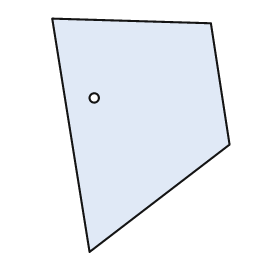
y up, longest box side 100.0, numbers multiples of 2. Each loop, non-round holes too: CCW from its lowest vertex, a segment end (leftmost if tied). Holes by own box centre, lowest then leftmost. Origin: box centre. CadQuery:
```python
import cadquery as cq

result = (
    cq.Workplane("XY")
    .moveTo(-22.0, -50.0)
    .lineTo(38.0, -4.0)
    .lineTo(30.0, 48.0)
    .lineTo(-38.0, 50.0)
    .close()
    .moveTo(-20.0, 16.0)
    .circle(2.0)
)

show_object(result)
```